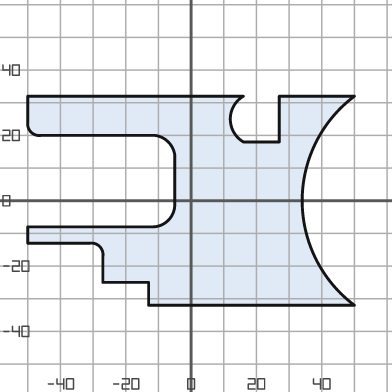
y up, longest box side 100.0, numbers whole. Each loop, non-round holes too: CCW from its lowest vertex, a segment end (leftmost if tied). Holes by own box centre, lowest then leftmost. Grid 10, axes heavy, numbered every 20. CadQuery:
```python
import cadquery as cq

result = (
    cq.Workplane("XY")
    .moveTo(-13.0, -32.0)
    .lineTo(50.0, -32.0)
    .threePointArc((34.0, 0.0), (50.0, 32.0))
    .lineTo(27.0, 32.0)
    .lineTo(27.0, 18.0)
    .lineTo(16.0, 18.0)
    .threePointArc((12.0, 25.0), (16.0, 32.0))
    .lineTo(-50.0, 32.0)
    .lineTo(-50.0, 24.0)
    .threePointArc((-49.0, 21.0), (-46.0, 20.0))
    .lineTo(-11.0, 20.0)
    .threePointArc((-7.0, 18.0), (-5.0, 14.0))
    .lineTo(-5.0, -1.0)
    .threePointArc((-7.0, -6.0), (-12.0, -8.0))
    .lineTo(-50.0, -8.0)
    .lineTo(-50.0, -13.0)
    .lineTo(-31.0, -13.0)
    .threePointArc((-28.0, -14.0), (-27.0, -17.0))
    .lineTo(-27.0, -25.0)
    .lineTo(-13.0, -25.0)
    .close()
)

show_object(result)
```